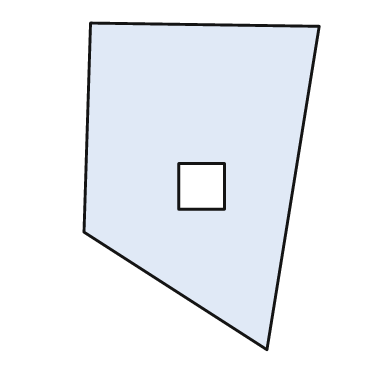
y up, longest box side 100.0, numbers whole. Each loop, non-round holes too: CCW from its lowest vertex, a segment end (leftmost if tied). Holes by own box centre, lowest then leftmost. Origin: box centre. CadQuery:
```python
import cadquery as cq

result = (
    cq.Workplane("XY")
    .moveTo(20.0, -50.0)
    .lineTo(36.0, 49.0)
    .lineTo(-34.0, 50.0)
    .lineTo(-36.0, -14.0)
    .close()
    .moveTo(-7.0, -7.0)
    .lineTo(7.0, -7.0)
    .lineTo(7.0, 7.0)
    .lineTo(-7.0, 7.0)
    .close()
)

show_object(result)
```